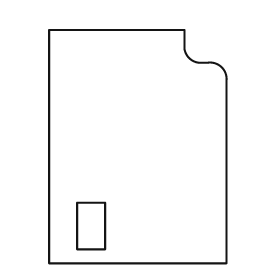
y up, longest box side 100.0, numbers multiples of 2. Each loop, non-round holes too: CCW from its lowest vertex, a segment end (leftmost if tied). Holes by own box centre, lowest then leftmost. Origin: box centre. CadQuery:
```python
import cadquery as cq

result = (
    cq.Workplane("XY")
    .moveTo(-38.0, -50.0)
    .lineTo(38.0, -50.0)
    .lineTo(38.0, 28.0)
    .threePointArc((36.0, 34.0), (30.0, 36.0))
    .lineTo(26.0, 36.0)
    .threePointArc((22.0, 38.0), (20.0, 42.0))
    .lineTo(20.0, 50.0)
    .lineTo(-38.0, 50.0)
    .close()
    .moveTo(-26.0, -44.0)
    .lineTo(-14.0, -44.0)
    .lineTo(-14.0, -24.0)
    .lineTo(-26.0, -24.0)
    .close()
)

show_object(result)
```